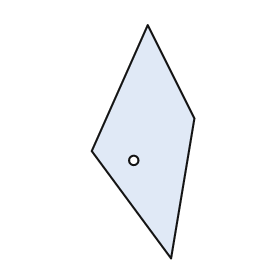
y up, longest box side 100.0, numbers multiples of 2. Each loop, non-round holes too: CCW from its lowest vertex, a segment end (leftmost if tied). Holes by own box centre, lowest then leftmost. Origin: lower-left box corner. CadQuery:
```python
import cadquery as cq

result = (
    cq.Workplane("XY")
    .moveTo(34.0, 0.0)
    .lineTo(44.0, 60.0)
    .lineTo(24.0, 100.0)
    .lineTo(0.0, 46.0)
    .close()
    .moveTo(18.0, 42.0)
    .circle(2.0)
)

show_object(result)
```